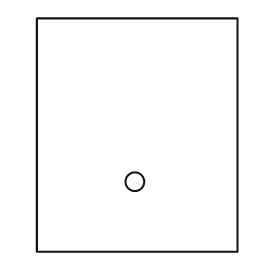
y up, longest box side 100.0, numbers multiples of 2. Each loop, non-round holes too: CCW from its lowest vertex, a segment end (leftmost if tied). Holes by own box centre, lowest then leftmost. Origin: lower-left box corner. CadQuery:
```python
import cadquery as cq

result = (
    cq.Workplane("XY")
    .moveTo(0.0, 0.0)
    .lineTo(86.0, 0.0)
    .lineTo(86.0, 100.0)
    .lineTo(0.0, 100.0)
    .close()
    .moveTo(42.0, 30.0)
    .circle(4.0)
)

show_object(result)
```